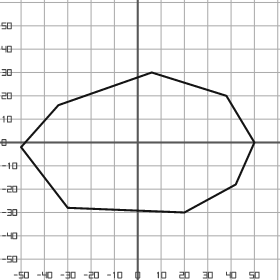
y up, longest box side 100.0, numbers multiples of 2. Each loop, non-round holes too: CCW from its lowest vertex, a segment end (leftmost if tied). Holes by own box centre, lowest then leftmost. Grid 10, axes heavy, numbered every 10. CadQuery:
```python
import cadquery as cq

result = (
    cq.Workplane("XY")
    .moveTo(20.0, -30.0)
    .lineTo(42.0, -18.0)
    .lineTo(50.0, 0.0)
    .lineTo(38.0, 20.0)
    .lineTo(6.0, 30.0)
    .lineTo(-34.0, 16.0)
    .lineTo(-50.0, -2.0)
    .lineTo(-30.0, -28.0)
    .close()
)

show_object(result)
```